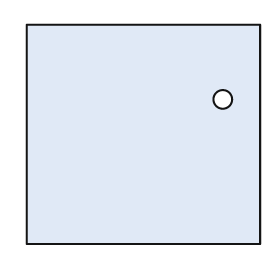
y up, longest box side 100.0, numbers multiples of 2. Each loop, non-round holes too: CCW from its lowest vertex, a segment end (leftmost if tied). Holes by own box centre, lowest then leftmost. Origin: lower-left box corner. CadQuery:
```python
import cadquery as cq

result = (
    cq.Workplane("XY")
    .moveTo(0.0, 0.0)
    .lineTo(100.0, 0.0)
    .lineTo(100.0, 94.0)
    .lineTo(0.0, 94.0)
    .close()
    .moveTo(84.0, 62.0)
    .circle(4.0)
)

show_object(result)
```